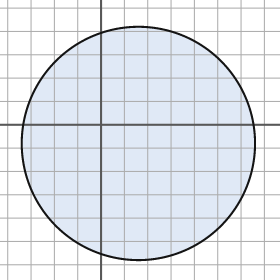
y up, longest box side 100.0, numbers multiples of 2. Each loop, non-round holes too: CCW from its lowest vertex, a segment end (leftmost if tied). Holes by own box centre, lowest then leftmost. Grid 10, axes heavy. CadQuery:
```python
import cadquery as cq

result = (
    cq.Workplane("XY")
    .moveTo(16.0, -8.0)
    .circle(50.0)
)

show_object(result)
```